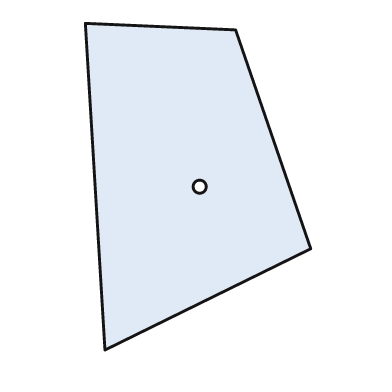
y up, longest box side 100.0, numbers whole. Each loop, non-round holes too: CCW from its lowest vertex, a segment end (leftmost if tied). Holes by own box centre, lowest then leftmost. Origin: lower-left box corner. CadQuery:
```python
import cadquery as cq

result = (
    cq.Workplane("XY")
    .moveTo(6.0, 0.0)
    .lineTo(69.0, 31.0)
    .lineTo(46.0, 98.0)
    .lineTo(0.0, 100.0)
    .close()
    .moveTo(35.0, 50.0)
    .circle(2.0)
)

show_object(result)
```